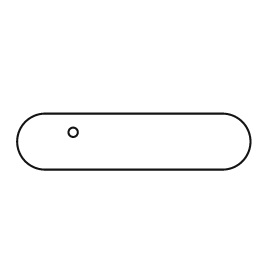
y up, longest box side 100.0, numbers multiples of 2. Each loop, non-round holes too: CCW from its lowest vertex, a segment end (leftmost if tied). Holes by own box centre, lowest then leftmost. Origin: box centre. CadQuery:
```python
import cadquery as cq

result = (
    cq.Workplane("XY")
    .moveTo(-38.0, -12.0)
    .lineTo(38.0, -12.0)
    .threePointArc((50.0, 0.0), (38.0, 12.0))
    .lineTo(-38.0, 12.0)
    .threePointArc((-50.0, 0.0), (-38.0, -12.0))
    .close()
    .moveTo(-26.0, 4.0)
    .circle(2.0)
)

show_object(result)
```